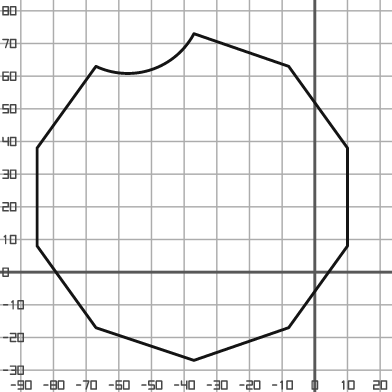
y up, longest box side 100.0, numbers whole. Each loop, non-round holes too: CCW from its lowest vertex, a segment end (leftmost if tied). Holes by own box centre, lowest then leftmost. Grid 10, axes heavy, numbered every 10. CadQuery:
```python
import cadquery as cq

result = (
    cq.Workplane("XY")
    .moveTo(-37.0, -27.0)
    .lineTo(-8.0, -17.0)
    .lineTo(10.0, 8.0)
    .lineTo(10.0, 38.0)
    .lineTo(-8.0, 63.0)
    .lineTo(-37.0, 73.0)
    .threePointArc((-50.0, 62.0), (-67.0, 63.0))
    .lineTo(-85.0, 38.0)
    .lineTo(-85.0, 8.0)
    .lineTo(-67.0, -17.0)
    .close()
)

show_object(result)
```